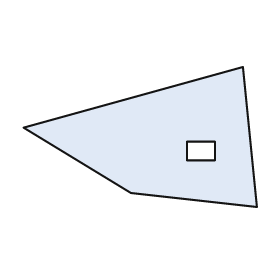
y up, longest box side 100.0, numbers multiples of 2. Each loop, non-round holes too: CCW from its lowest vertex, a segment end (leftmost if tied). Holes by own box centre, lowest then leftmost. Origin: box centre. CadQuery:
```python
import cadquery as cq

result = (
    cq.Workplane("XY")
    .moveTo(50.0, -30.0)
    .lineTo(44.0, 30.0)
    .lineTo(-50.0, 4.0)
    .lineTo(-4.0, -24.0)
    .close()
    .moveTo(20.0, -10.0)
    .lineTo(32.0, -10.0)
    .lineTo(32.0, -2.0)
    .lineTo(20.0, -2.0)
    .close()
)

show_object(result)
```